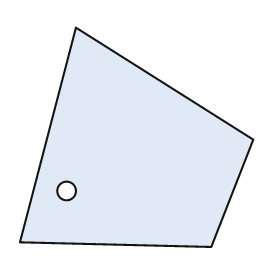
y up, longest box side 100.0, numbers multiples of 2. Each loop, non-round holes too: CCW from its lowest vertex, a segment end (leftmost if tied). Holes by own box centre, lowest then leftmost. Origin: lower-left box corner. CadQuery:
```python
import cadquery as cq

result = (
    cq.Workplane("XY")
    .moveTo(82.0, 0.0)
    .lineTo(100.0, 46.0)
    .lineTo(24.0, 94.0)
    .lineTo(0.0, 2.0)
    .close()
    .moveTo(20.0, 24.0)
    .circle(4.0)
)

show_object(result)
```